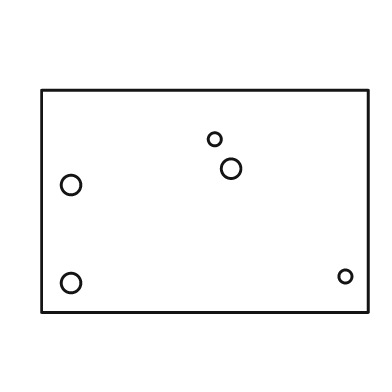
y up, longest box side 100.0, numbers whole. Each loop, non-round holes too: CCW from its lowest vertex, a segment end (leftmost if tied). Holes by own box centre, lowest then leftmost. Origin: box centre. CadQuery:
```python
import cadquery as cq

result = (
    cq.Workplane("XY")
    .moveTo(-50.0, -34.0)
    .lineTo(50.0, -34.0)
    .lineTo(50.0, 34.0)
    .lineTo(-50.0, 34.0)
    .close()
    .moveTo(-41.0, -25.0)
    .circle(3.0)
    .moveTo(43.0, -23.0)
    .circle(2.0)
    .moveTo(-41.0, 5.0)
    .circle(3.0)
    .moveTo(8.0, 10.0)
    .circle(3.0)
    .moveTo(3.0, 19.0)
    .circle(2.0)
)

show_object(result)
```